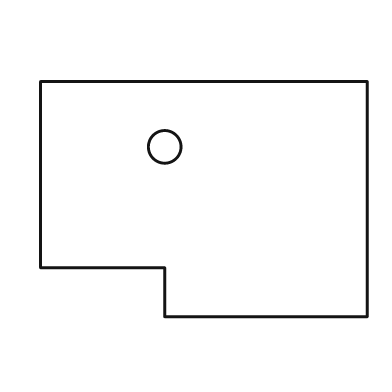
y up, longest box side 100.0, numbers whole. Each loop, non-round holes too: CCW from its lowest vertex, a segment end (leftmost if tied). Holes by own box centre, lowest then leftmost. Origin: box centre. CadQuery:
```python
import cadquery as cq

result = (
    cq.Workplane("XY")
    .moveTo(-12.0, -36.0)
    .lineTo(50.0, -36.0)
    .lineTo(50.0, 36.0)
    .lineTo(-50.0, 36.0)
    .lineTo(-50.0, -21.0)
    .lineTo(-12.0, -21.0)
    .close()
    .moveTo(-12.0, 16.0)
    .circle(5.0)
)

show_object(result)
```